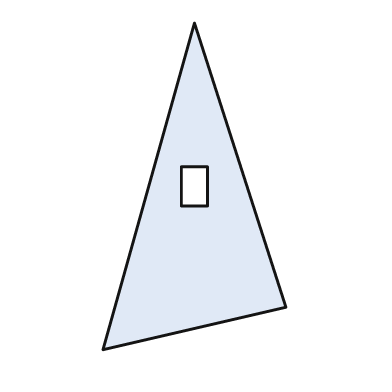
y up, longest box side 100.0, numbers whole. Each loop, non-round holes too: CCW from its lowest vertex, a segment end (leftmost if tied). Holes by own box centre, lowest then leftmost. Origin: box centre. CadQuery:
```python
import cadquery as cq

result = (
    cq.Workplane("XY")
    .moveTo(-28.0, -50.0)
    .lineTo(28.0, -37.0)
    .lineTo(0.0, 50.0)
    .close()
    .moveTo(-4.0, -6.0)
    .lineTo(4.0, -6.0)
    .lineTo(4.0, 6.0)
    .lineTo(-4.0, 6.0)
    .close()
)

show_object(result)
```